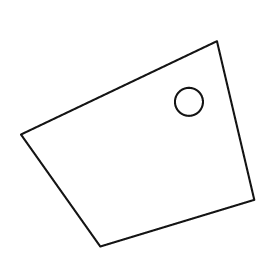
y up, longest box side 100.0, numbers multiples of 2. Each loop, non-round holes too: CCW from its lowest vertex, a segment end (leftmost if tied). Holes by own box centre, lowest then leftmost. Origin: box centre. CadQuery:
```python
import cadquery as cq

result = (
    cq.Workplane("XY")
    .moveTo(-16.0, -44.0)
    .lineTo(50.0, -24.0)
    .lineTo(34.0, 44.0)
    .lineTo(-50.0, 4.0)
    .close()
    .moveTo(22.0, 18.0)
    .circle(6.0)
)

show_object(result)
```